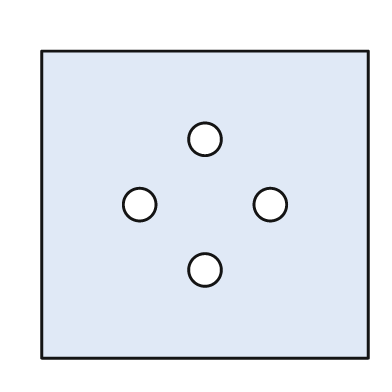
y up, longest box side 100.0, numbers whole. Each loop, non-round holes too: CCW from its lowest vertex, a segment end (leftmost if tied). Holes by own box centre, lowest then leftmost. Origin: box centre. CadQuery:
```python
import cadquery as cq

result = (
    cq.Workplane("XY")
    .moveTo(-50.0, -47.0)
    .lineTo(50.0, -47.0)
    .lineTo(50.0, 47.0)
    .lineTo(-50.0, 47.0)
    .close()
    .moveTo(0.0, -20.0)
    .circle(5.0)
    .moveTo(-20.0, 0.0)
    .circle(5.0)
    .moveTo(20.0, 0.0)
    .circle(5.0)
    .moveTo(0.0, 20.0)
    .circle(5.0)
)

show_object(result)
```